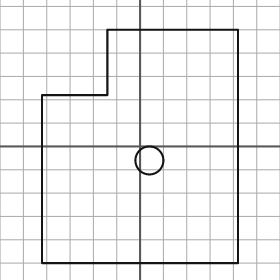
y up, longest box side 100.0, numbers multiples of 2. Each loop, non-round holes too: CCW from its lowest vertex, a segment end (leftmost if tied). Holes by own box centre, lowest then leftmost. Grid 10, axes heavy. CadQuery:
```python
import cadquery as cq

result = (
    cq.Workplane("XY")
    .moveTo(-42.0, -50.0)
    .lineTo(42.0, -50.0)
    .lineTo(42.0, 50.0)
    .lineTo(-14.0, 50.0)
    .lineTo(-14.0, 22.0)
    .lineTo(-42.0, 22.0)
    .close()
    .moveTo(4.0, -6.0)
    .circle(6.0)
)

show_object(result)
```